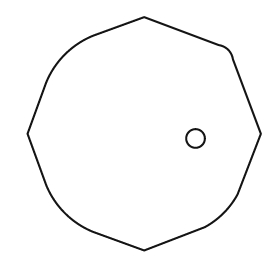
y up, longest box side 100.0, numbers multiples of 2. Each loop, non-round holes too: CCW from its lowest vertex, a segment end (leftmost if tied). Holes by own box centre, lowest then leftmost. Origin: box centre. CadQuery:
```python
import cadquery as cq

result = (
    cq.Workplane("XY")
    .moveTo(0.0, -50.0)
    .lineTo(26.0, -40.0)
    .threePointArc((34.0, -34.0), (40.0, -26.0))
    .lineTo(50.0, 0.0)
    .lineTo(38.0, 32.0)
    .threePointArc((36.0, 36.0), (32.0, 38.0))
    .lineTo(0.0, 50.0)
    .lineTo(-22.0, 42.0)
    .threePointArc((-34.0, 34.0), (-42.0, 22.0))
    .lineTo(-50.0, 0.0)
    .lineTo(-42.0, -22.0)
    .threePointArc((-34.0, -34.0), (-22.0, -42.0))
    .close()
    .moveTo(22.0, -2.0)
    .circle(4.0)
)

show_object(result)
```